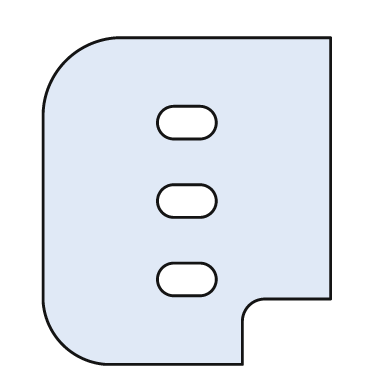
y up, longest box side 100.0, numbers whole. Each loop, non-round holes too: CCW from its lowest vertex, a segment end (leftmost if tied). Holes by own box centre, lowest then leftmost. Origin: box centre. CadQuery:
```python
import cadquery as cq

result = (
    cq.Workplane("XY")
    .moveTo(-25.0, -50.0)
    .lineTo(17.0, -50.0)
    .lineTo(17.0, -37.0)
    .threePointArc((19.0, -32.0), (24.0, -30.0))
    .lineTo(44.0, -30.0)
    .lineTo(44.0, 50.0)
    .lineTo(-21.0, 50.0)
    .threePointArc((-37.0, 43.0), (-44.0, 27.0))
    .lineTo(-44.0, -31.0)
    .threePointArc((-38.0, -44.0), (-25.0, -50.0))
    .close()
    .moveTo(-4.0, -29.0)
    .lineTo(4.0, -29.0)
    .threePointArc((9.0, -24.0), (4.0, -19.0))
    .lineTo(-4.0, -19.0)
    .threePointArc((-9.0, -24.0), (-4.0, -29.0))
    .close()
    .moveTo(-4.0, -5.0)
    .lineTo(4.0, -5.0)
    .threePointArc((9.0, 0.0), (4.0, 5.0))
    .lineTo(-4.0, 5.0)
    .threePointArc((-9.0, 0.0), (-4.0, -5.0))
    .close()
    .moveTo(-4.0, 19.0)
    .lineTo(4.0, 19.0)
    .threePointArc((9.0, 24.0), (4.0, 29.0))
    .lineTo(-4.0, 29.0)
    .threePointArc((-9.0, 24.0), (-4.0, 19.0))
    .close()
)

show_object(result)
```